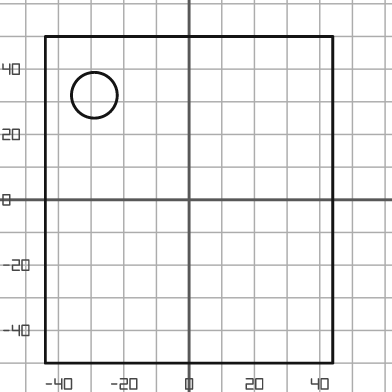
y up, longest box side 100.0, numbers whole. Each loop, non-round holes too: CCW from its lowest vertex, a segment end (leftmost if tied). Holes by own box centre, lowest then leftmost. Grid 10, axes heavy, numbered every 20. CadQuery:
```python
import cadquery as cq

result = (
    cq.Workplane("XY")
    .moveTo(-44.0, -50.0)
    .lineTo(44.0, -50.0)
    .lineTo(44.0, 50.0)
    .lineTo(-44.0, 50.0)
    .close()
    .moveTo(-29.0, 32.0)
    .circle(7.0)
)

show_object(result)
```